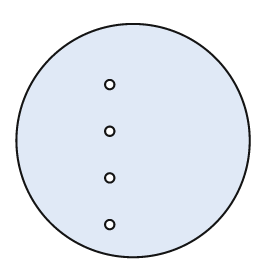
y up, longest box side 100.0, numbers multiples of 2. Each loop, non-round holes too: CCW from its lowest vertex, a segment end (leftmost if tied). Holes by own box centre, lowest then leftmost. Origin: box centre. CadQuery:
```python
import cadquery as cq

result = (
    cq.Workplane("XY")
    .moveTo(0.0, 0.0)
    .circle(50.0)
    .moveTo(-10.0, -36.0)
    .circle(2.0)
    .moveTo(-10.0, -16.0)
    .circle(2.0)
    .moveTo(-10.0, 4.0)
    .circle(2.0)
    .moveTo(-10.0, 24.0)
    .circle(2.0)
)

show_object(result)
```